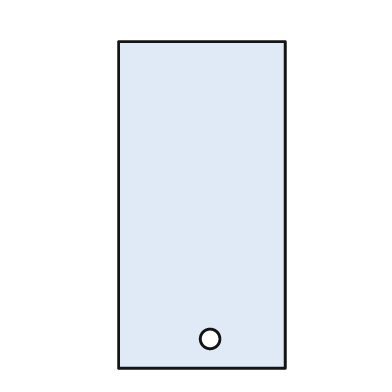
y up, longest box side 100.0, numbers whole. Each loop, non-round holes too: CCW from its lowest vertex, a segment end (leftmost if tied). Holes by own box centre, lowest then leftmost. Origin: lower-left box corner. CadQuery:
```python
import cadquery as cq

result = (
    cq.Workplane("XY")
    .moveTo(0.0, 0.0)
    .lineTo(51.0, 0.0)
    .lineTo(51.0, 100.0)
    .lineTo(0.0, 100.0)
    .close()
    .moveTo(28.0, 9.0)
    .circle(3.0)
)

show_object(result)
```